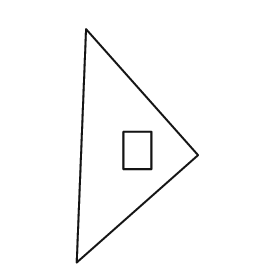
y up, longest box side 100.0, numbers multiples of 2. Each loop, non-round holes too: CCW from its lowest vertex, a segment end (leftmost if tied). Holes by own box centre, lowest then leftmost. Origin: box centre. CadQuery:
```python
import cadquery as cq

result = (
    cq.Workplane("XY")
    .moveTo(-26.0, -50.0)
    .lineTo(26.0, -4.0)
    .lineTo(-22.0, 50.0)
    .close()
    .moveTo(-6.0, -10.0)
    .lineTo(6.0, -10.0)
    .lineTo(6.0, 6.0)
    .lineTo(-6.0, 6.0)
    .close()
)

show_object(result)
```